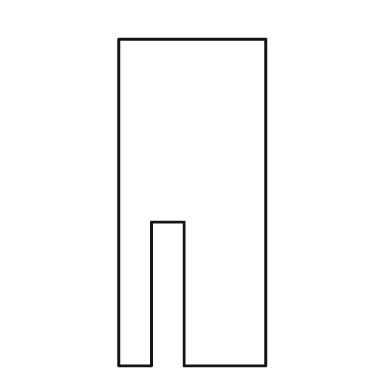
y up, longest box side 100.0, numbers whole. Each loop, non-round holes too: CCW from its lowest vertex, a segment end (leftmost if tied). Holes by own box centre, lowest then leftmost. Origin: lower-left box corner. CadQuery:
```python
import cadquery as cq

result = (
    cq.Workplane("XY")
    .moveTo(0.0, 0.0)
    .lineTo(10.0, 0.0)
    .lineTo(10.0, 44.0)
    .lineTo(20.0, 44.0)
    .lineTo(20.0, 0.0)
    .lineTo(45.0, 0.0)
    .lineTo(45.0, 100.0)
    .lineTo(0.0, 100.0)
    .close()
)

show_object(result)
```